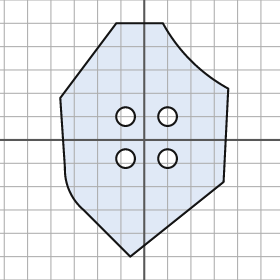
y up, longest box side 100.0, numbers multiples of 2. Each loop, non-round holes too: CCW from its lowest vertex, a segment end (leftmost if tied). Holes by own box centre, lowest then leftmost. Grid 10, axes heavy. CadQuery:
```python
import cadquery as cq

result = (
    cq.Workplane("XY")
    .moveTo(-6.0, -50.0)
    .lineTo(34.0, -18.0)
    .lineTo(36.0, 22.0)
    .threePointArc((20.0, 34.0), (8.0, 50.0))
    .lineTo(-12.0, 50.0)
    .lineTo(-36.0, 18.0)
    .lineTo(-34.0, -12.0)
    .threePointArc((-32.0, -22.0), (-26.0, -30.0))
    .close()
    .moveTo(-8.0, -8.0)
    .circle(4.0)
    .moveTo(10.0, -8.0)
    .circle(4.0)
    .moveTo(-8.0, 10.0)
    .circle(4.0)
    .moveTo(10.0, 10.0)
    .circle(4.0)
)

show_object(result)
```